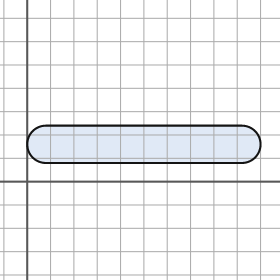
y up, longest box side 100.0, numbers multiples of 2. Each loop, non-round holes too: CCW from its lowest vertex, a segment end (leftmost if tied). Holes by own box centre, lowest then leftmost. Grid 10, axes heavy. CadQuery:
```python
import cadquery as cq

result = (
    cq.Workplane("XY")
    .moveTo(8.0, 8.0)
    .lineTo(92.0, 8.0)
    .threePointArc((100.0, 16.0), (92.0, 24.0))
    .lineTo(8.0, 24.0)
    .threePointArc((0.0, 16.0), (8.0, 8.0))
    .close()
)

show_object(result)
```